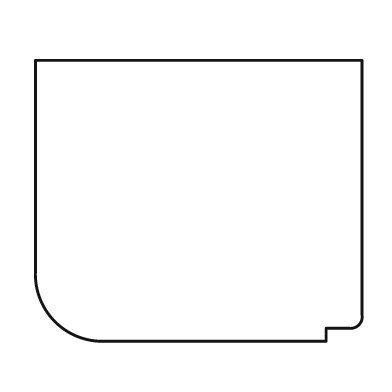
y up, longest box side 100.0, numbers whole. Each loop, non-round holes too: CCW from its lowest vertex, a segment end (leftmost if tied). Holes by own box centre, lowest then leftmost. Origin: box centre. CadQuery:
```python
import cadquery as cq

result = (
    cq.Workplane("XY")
    .moveTo(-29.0, -43.0)
    .lineTo(39.0, -43.0)
    .lineTo(39.0, -39.0)
    .lineTo(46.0, -39.0)
    .threePointArc((49.0, -38.0), (50.0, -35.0))
    .lineTo(50.0, 43.0)
    .lineTo(-50.0, 43.0)
    .lineTo(-50.0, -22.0)
    .threePointArc((-44.0, -37.0), (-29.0, -43.0))
    .close()
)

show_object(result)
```